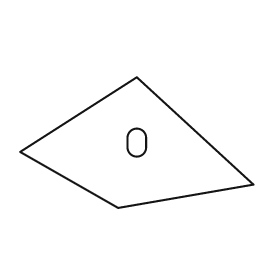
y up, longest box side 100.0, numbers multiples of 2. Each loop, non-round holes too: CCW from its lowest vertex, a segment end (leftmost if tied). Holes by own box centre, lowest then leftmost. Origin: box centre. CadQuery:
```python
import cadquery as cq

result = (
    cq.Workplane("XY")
    .moveTo(-8.0, -28.0)
    .lineTo(50.0, -18.0)
    .lineTo(0.0, 28.0)
    .lineTo(-50.0, -4.0)
    .close()
    .moveTo(-4.0, -2.0)
    .threePointArc((0.0, -6.0), (4.0, -2.0))
    .lineTo(4.0, 2.0)
    .threePointArc((0.0, 6.0), (-4.0, 2.0))
    .close()
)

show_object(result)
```